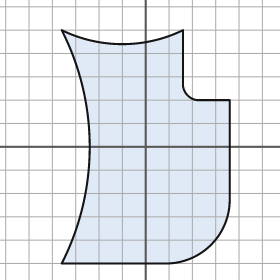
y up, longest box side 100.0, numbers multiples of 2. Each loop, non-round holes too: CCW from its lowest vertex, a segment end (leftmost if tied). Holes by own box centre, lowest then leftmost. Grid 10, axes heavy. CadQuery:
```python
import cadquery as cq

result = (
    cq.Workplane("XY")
    .moveTo(-36.0, -50.0)
    .lineTo(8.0, -50.0)
    .threePointArc((28.0, -42.0), (36.0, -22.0))
    .lineTo(36.0, 20.0)
    .lineTo(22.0, 20.0)
    .threePointArc((18.0, 22.0), (16.0, 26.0))
    .lineTo(16.0, 50.0)
    .threePointArc((-10.0, 44.0), (-36.0, 50.0))
    .threePointArc((-24.0, 0.0), (-36.0, -50.0))
    .close()
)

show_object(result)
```